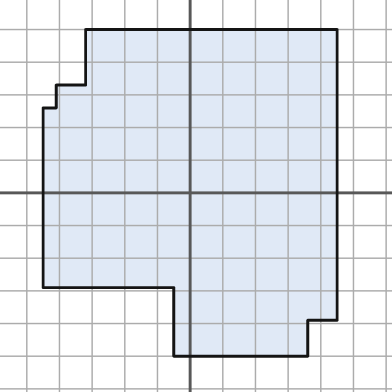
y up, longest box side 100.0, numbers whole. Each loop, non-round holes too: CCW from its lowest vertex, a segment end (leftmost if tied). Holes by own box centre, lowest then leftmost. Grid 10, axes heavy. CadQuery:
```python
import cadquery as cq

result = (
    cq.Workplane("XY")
    .moveTo(-5.0, -50.0)
    .lineTo(36.0, -50.0)
    .lineTo(36.0, -39.0)
    .lineTo(45.0, -39.0)
    .lineTo(45.0, 50.0)
    .lineTo(-32.0, 50.0)
    .lineTo(-32.0, 33.0)
    .lineTo(-41.0, 33.0)
    .lineTo(-41.0, 26.0)
    .lineTo(-45.0, 26.0)
    .lineTo(-45.0, -29.0)
    .lineTo(-5.0, -29.0)
    .close()
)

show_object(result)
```